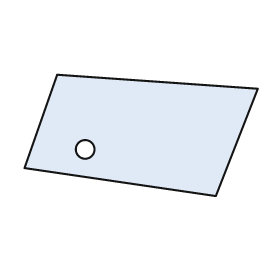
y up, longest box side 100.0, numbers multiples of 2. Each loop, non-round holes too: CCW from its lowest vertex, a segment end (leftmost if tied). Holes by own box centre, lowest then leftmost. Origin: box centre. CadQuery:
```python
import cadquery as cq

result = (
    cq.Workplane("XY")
    .moveTo(32.0, -26.0)
    .lineTo(50.0, 20.0)
    .lineTo(-36.0, 26.0)
    .lineTo(-50.0, -14.0)
    .close()
    .moveTo(-24.0, -6.0)
    .circle(4.0)
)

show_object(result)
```